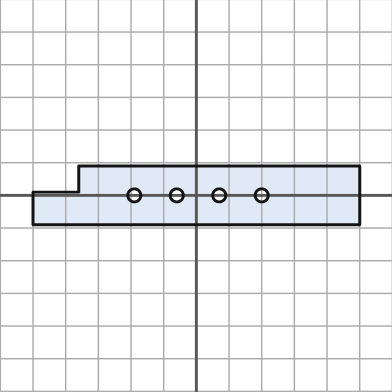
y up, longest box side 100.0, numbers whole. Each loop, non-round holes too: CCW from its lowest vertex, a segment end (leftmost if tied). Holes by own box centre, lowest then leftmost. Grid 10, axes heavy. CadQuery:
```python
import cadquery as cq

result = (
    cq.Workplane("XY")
    .moveTo(-50.0, -9.0)
    .lineTo(50.0, -9.0)
    .lineTo(50.0, 9.0)
    .lineTo(-36.0, 9.0)
    .lineTo(-36.0, 1.0)
    .lineTo(-50.0, 1.0)
    .close()
    .moveTo(-19.0, 0.0)
    .circle(2.0)
    .moveTo(-6.0, 0.0)
    .circle(2.0)
    .moveTo(7.0, 0.0)
    .circle(2.0)
    .moveTo(20.0, 0.0)
    .circle(2.0)
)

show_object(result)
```